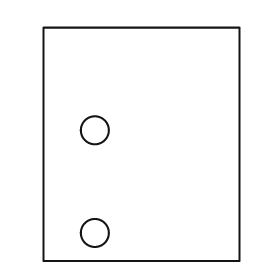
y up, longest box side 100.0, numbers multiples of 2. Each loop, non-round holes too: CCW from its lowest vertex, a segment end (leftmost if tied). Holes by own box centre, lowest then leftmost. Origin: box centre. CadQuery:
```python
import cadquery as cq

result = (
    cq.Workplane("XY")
    .moveTo(-42.0, -50.0)
    .lineTo(42.0, -50.0)
    .lineTo(42.0, 50.0)
    .lineTo(-42.0, 50.0)
    .close()
    .moveTo(-20.0, -38.0)
    .circle(6.0)
    .moveTo(-20.0, 6.0)
    .circle(6.0)
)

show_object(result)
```